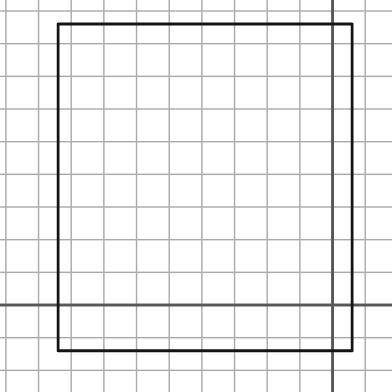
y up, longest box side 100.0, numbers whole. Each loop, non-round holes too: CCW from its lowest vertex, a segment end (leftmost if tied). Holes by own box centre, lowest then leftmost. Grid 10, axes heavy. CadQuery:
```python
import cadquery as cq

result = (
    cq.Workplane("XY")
    .moveTo(-84.0, -14.0)
    .lineTo(6.0, -14.0)
    .lineTo(6.0, 86.0)
    .lineTo(-84.0, 86.0)
    .close()
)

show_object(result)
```